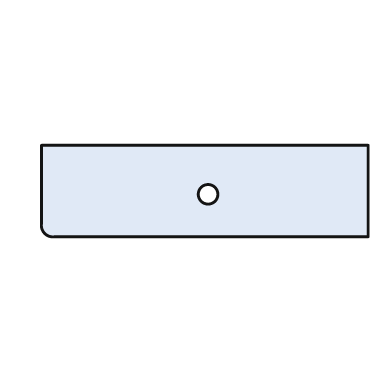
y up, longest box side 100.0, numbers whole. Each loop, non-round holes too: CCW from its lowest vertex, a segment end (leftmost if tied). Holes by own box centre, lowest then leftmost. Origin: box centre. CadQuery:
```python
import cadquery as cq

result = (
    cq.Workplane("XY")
    .moveTo(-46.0, -14.0)
    .lineTo(50.0, -14.0)
    .lineTo(50.0, 14.0)
    .lineTo(-50.0, 14.0)
    .lineTo(-50.0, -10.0)
    .threePointArc((-49.0, -13.0), (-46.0, -14.0))
    .close()
    .moveTo(1.0, -1.0)
    .circle(3.0)
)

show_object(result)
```